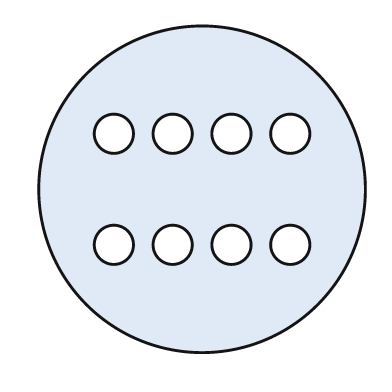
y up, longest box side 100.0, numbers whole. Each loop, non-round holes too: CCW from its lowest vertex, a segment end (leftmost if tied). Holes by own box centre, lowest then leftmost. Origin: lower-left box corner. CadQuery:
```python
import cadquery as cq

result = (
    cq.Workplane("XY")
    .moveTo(50.0, 50.0)
    .circle(50.0)
    .moveTo(23.0, 33.0)
    .circle(6.0)
    .moveTo(41.0, 33.0)
    .circle(6.0)
    .moveTo(59.0, 33.0)
    .circle(6.0)
    .moveTo(77.0, 33.0)
    .circle(6.0)
    .moveTo(23.0, 67.0)
    .circle(6.0)
    .moveTo(41.0, 67.0)
    .circle(6.0)
    .moveTo(59.0, 67.0)
    .circle(6.0)
    .moveTo(77.0, 67.0)
    .circle(6.0)
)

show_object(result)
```